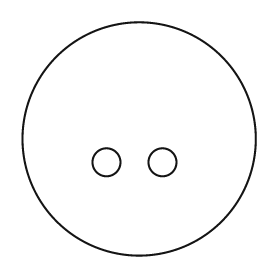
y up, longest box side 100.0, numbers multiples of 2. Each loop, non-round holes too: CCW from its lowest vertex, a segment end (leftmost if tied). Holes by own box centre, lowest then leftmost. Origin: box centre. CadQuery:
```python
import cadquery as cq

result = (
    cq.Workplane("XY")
    .moveTo(0.0, 0.0)
    .circle(50.0)
    .moveTo(-14.0, -10.0)
    .circle(6.0)
    .moveTo(10.0, -10.0)
    .circle(6.0)
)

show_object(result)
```